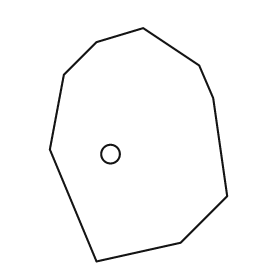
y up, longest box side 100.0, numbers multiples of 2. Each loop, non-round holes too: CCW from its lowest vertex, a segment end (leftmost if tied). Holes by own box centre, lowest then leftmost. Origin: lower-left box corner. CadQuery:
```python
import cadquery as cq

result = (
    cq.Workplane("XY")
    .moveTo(20.0, 0.0)
    .lineTo(56.0, 8.0)
    .lineTo(76.0, 28.0)
    .lineTo(70.0, 70.0)
    .lineTo(64.0, 84.0)
    .lineTo(40.0, 100.0)
    .lineTo(20.0, 94.0)
    .lineTo(6.0, 80.0)
    .lineTo(0.0, 48.0)
    .close()
    .moveTo(26.0, 46.0)
    .circle(4.0)
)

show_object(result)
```